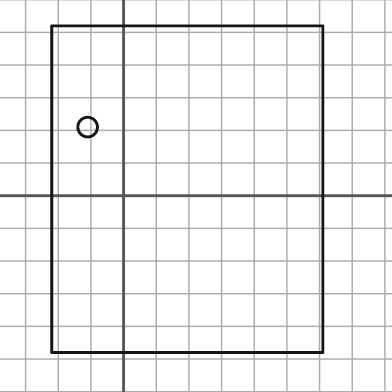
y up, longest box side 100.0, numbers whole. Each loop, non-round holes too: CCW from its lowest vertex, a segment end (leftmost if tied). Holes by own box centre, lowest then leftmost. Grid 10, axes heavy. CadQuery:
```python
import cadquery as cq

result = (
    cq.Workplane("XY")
    .moveTo(-22.0, -48.0)
    .lineTo(61.0, -48.0)
    .lineTo(61.0, 52.0)
    .lineTo(-22.0, 52.0)
    .close()
    .moveTo(-11.0, 21.0)
    .circle(3.0)
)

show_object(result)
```